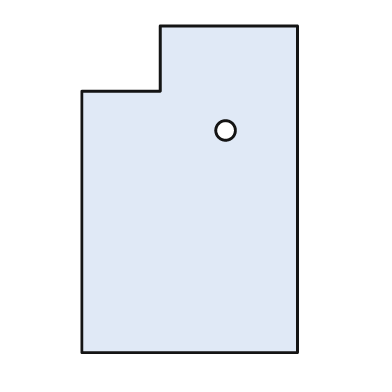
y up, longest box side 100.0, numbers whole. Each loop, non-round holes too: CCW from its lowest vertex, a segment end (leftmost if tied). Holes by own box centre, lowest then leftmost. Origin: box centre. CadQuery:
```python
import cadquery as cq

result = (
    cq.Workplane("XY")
    .moveTo(-33.0, -50.0)
    .lineTo(33.0, -50.0)
    .lineTo(33.0, 50.0)
    .lineTo(-9.0, 50.0)
    .lineTo(-9.0, 30.0)
    .lineTo(-33.0, 30.0)
    .close()
    .moveTo(11.0, 18.0)
    .circle(3.0)
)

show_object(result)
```